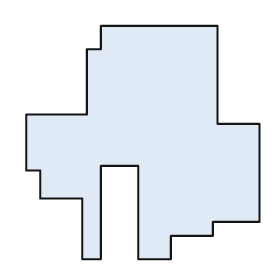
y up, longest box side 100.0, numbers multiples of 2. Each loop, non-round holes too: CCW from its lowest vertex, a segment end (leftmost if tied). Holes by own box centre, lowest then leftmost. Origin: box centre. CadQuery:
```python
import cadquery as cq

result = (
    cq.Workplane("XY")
    .moveTo(-26.0, -50.0)
    .lineTo(-18.0, -50.0)
    .lineTo(-18.0, -10.0)
    .lineTo(-2.0, -10.0)
    .lineTo(-2.0, -50.0)
    .lineTo(12.0, -50.0)
    .lineTo(12.0, -40.0)
    .lineTo(30.0, -40.0)
    .lineTo(30.0, -34.0)
    .lineTo(50.0, -34.0)
    .lineTo(50.0, 8.0)
    .lineTo(32.0, 8.0)
    .lineTo(32.0, 50.0)
    .lineTo(-18.0, 50.0)
    .lineTo(-18.0, 40.0)
    .lineTo(-24.0, 40.0)
    .lineTo(-24.0, 12.0)
    .lineTo(-50.0, 12.0)
    .lineTo(-50.0, -12.0)
    .lineTo(-44.0, -12.0)
    .lineTo(-44.0, -24.0)
    .lineTo(-26.0, -24.0)
    .close()
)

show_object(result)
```